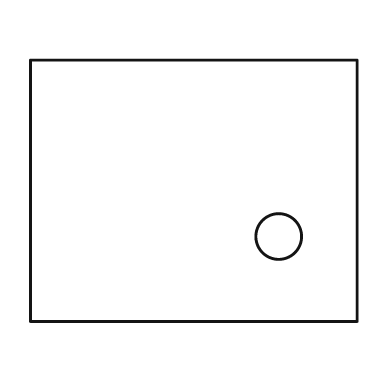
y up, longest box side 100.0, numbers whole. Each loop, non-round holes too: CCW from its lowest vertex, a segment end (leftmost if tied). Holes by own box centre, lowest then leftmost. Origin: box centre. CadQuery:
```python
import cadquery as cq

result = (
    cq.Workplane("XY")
    .moveTo(-50.0, -40.0)
    .lineTo(50.0, -40.0)
    .lineTo(50.0, 40.0)
    .lineTo(-50.0, 40.0)
    .close()
    .moveTo(26.0, -14.0)
    .circle(7.0)
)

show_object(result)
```